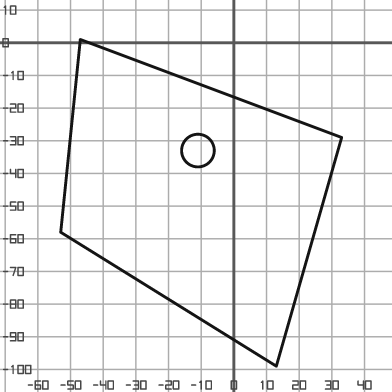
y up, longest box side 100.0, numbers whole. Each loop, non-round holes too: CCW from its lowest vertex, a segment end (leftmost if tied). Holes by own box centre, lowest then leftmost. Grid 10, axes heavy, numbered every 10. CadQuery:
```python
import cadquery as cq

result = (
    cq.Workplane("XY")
    .moveTo(13.0, -99.0)
    .lineTo(33.0, -29.0)
    .lineTo(-47.0, 1.0)
    .lineTo(-53.0, -58.0)
    .close()
    .moveTo(-11.0, -33.0)
    .circle(5.0)
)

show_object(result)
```